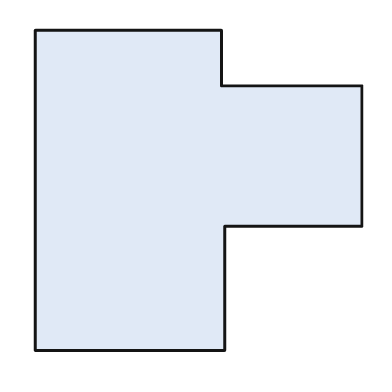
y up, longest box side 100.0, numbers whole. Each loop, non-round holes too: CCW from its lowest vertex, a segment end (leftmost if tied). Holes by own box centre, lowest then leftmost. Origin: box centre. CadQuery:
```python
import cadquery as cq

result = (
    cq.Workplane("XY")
    .moveTo(-50.0, -49.0)
    .lineTo(8.0, -49.0)
    .lineTo(8.0, -11.0)
    .lineTo(50.0, -11.0)
    .lineTo(50.0, 32.0)
    .lineTo(7.0, 32.0)
    .lineTo(7.0, 49.0)
    .lineTo(-50.0, 49.0)
    .close()
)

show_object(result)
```